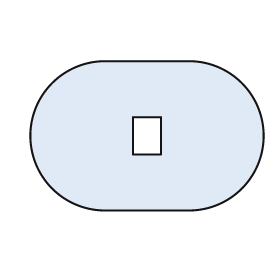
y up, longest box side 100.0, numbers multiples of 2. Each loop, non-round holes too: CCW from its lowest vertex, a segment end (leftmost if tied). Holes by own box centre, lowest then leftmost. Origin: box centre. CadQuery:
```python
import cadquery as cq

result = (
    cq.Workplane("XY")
    .moveTo(-18.0, -32.0)
    .lineTo(18.0, -32.0)
    .threePointArc((50.0, 0.0), (18.0, 32.0))
    .lineTo(-18.0, 32.0)
    .threePointArc((-50.0, 0.0), (-18.0, -32.0))
    .close()
    .moveTo(-6.0, -8.0)
    .lineTo(6.0, -8.0)
    .lineTo(6.0, 8.0)
    .lineTo(-6.0, 8.0)
    .close()
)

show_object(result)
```